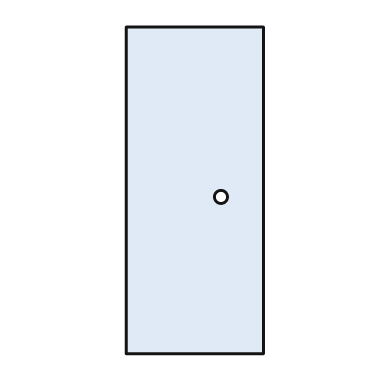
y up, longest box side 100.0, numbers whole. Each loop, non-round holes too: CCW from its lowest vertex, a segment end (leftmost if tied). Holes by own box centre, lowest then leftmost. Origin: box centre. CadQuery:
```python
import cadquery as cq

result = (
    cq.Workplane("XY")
    .moveTo(-21.0, -50.0)
    .lineTo(21.0, -50.0)
    .lineTo(21.0, 50.0)
    .lineTo(-21.0, 50.0)
    .close()
    .moveTo(8.0, -2.0)
    .circle(2.0)
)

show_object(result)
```